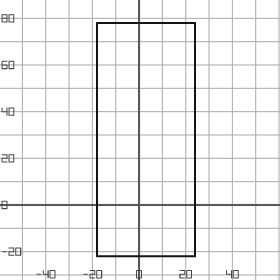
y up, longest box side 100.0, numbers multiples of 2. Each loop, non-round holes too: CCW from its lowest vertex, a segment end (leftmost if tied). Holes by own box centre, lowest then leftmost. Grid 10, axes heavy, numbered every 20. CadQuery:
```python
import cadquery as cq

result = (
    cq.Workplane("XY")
    .moveTo(-18.0, -22.0)
    .lineTo(24.0, -22.0)
    .lineTo(24.0, 78.0)
    .lineTo(-18.0, 78.0)
    .close()
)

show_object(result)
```